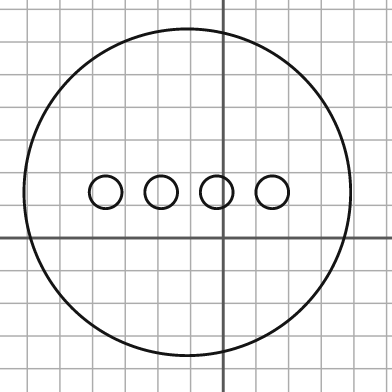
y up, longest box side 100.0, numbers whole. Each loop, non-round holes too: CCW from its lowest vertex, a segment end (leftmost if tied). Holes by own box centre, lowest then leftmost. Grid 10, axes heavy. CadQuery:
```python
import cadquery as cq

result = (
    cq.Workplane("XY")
    .moveTo(-11.0, 14.0)
    .circle(50.0)
    .moveTo(-36.0, 14.0)
    .circle(5.0)
    .moveTo(-19.0, 14.0)
    .circle(5.0)
    .moveTo(-2.0, 14.0)
    .circle(5.0)
    .moveTo(15.0, 14.0)
    .circle(5.0)
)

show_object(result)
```